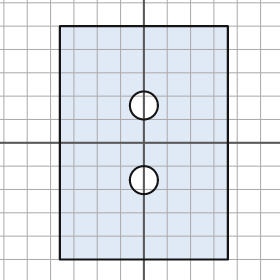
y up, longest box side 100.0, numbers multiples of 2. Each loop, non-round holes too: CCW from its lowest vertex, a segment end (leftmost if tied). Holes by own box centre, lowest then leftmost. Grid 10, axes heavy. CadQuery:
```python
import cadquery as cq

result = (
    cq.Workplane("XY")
    .moveTo(-36.0, -50.0)
    .lineTo(36.0, -50.0)
    .lineTo(36.0, 50.0)
    .lineTo(-36.0, 50.0)
    .close()
    .moveTo(0.0, -16.0)
    .circle(6.0)
    .moveTo(0.0, 16.0)
    .circle(6.0)
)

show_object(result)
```